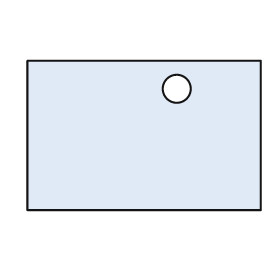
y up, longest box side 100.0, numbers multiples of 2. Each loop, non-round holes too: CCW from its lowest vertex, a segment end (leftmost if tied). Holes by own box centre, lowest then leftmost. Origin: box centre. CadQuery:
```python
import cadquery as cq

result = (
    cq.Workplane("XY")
    .moveTo(-50.0, -32.0)
    .lineTo(50.0, -32.0)
    .lineTo(50.0, 32.0)
    .lineTo(-50.0, 32.0)
    .close()
    .moveTo(14.0, 20.0)
    .circle(6.0)
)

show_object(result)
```